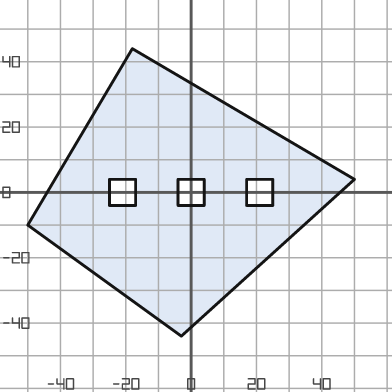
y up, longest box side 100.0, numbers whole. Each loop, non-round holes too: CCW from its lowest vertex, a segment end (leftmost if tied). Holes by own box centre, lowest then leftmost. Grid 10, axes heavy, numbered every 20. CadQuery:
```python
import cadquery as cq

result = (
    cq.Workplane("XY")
    .moveTo(-3.0, -44.0)
    .lineTo(50.0, 4.0)
    .lineTo(-18.0, 44.0)
    .lineTo(-50.0, -10.0)
    .close()
    .moveTo(-25.0, -4.0)
    .lineTo(-17.0, -4.0)
    .lineTo(-17.0, 4.0)
    .lineTo(-25.0, 4.0)
    .close()
    .moveTo(-4.0, -4.0)
    .lineTo(4.0, -4.0)
    .lineTo(4.0, 4.0)
    .lineTo(-4.0, 4.0)
    .close()
    .moveTo(17.0, -4.0)
    .lineTo(25.0, -4.0)
    .lineTo(25.0, 4.0)
    .lineTo(17.0, 4.0)
    .close()
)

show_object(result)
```